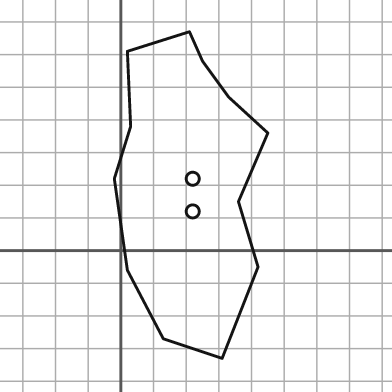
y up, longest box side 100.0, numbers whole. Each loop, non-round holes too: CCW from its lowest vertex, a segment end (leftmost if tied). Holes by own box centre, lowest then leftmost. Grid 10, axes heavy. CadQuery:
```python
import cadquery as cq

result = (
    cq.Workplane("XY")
    .moveTo(31.0, -33.0)
    .lineTo(42.0, -5.0)
    .lineTo(36.0, 15.0)
    .lineTo(45.0, 36.0)
    .lineTo(33.0, 47.0)
    .lineTo(25.0, 58.0)
    .lineTo(21.0, 67.0)
    .lineTo(2.0, 61.0)
    .lineTo(3.0, 38.0)
    .lineTo(-2.0, 22.0)
    .lineTo(2.0, -6.0)
    .lineTo(13.0, -27.0)
    .close()
    .moveTo(22.0, 12.0)
    .circle(2.0)
    .moveTo(22.0, 22.0)
    .circle(2.0)
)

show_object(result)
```